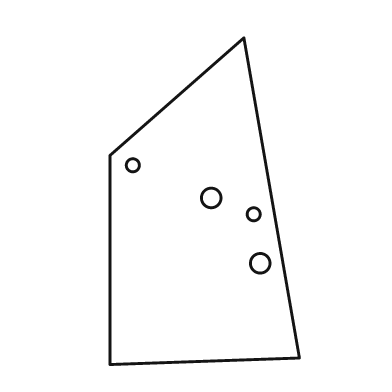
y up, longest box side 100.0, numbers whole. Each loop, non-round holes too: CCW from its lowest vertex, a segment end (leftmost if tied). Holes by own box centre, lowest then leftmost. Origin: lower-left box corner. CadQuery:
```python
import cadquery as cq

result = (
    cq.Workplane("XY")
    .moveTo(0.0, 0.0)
    .lineTo(58.0, 2.0)
    .lineTo(41.0, 100.0)
    .lineTo(0.0, 64.0)
    .close()
    .moveTo(46.0, 31.0)
    .circle(3.0)
    .moveTo(44.0, 46.0)
    .circle(2.0)
    .moveTo(31.0, 51.0)
    .circle(3.0)
    .moveTo(7.0, 61.0)
    .circle(2.0)
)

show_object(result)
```